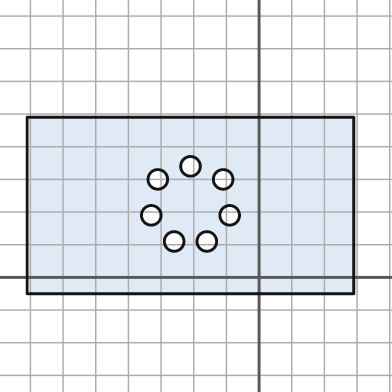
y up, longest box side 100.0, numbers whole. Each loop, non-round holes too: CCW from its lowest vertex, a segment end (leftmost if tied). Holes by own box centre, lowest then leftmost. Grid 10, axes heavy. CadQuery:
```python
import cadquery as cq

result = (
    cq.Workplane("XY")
    .moveTo(-71.0, -5.0)
    .lineTo(29.0, -5.0)
    .lineTo(29.0, 49.0)
    .lineTo(-71.0, 49.0)
    .close()
    .moveTo(-26.0, 11.0)
    .circle(3.0)
    .moveTo(-16.0, 11.0)
    .circle(3.0)
    .moveTo(-33.0, 19.0)
    .circle(3.0)
    .moveTo(-9.0, 19.0)
    .circle(3.0)
    .moveTo(-31.0, 30.0)
    .circle(3.0)
    .moveTo(-11.0, 30.0)
    .circle(3.0)
    .moveTo(-21.0, 34.0)
    .circle(3.0)
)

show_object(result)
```